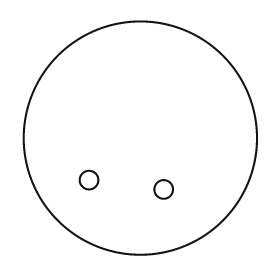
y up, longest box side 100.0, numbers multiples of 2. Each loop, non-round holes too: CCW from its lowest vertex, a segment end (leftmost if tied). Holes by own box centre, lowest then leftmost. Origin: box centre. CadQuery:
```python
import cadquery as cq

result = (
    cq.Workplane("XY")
    .moveTo(0.0, 0.0)
    .circle(50.0)
    .moveTo(10.0, -22.0)
    .circle(4.0)
    .moveTo(-22.0, -18.0)
    .circle(4.0)
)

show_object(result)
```